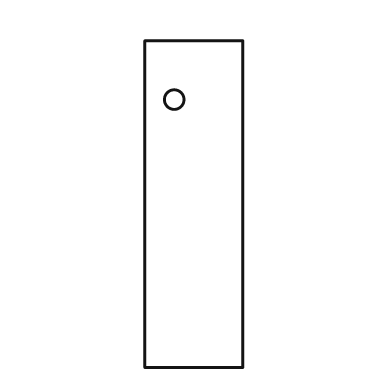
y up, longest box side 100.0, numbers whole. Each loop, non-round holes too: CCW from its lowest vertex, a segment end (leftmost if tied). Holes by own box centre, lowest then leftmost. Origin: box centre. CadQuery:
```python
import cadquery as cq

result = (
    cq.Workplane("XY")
    .moveTo(-15.0, -50.0)
    .lineTo(15.0, -50.0)
    .lineTo(15.0, 50.0)
    .lineTo(-15.0, 50.0)
    .close()
    .moveTo(-6.0, 32.0)
    .circle(3.0)
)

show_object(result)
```